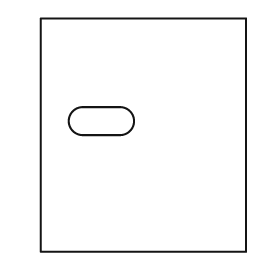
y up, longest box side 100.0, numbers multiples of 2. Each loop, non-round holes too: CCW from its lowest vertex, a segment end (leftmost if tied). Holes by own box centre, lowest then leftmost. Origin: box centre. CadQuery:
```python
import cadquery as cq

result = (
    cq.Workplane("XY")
    .moveTo(-44.0, -50.0)
    .lineTo(44.0, -50.0)
    .lineTo(44.0, 50.0)
    .lineTo(-44.0, 50.0)
    .close()
    .moveTo(-26.0, 0.0)
    .lineTo(-10.0, 0.0)
    .threePointArc((-4.0, 6.0), (-10.0, 12.0))
    .lineTo(-26.0, 12.0)
    .threePointArc((-32.0, 6.0), (-26.0, 0.0))
    .close()
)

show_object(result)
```